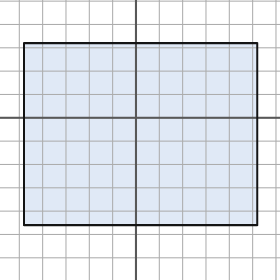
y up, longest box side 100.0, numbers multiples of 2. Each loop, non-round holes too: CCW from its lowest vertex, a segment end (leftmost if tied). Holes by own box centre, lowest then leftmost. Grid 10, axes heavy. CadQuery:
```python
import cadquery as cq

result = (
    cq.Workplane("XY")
    .moveTo(-48.0, -46.0)
    .lineTo(52.0, -46.0)
    .lineTo(52.0, 32.0)
    .lineTo(-48.0, 32.0)
    .close()
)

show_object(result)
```